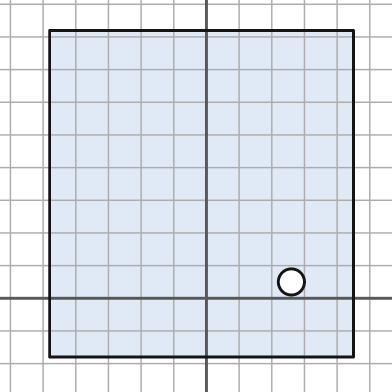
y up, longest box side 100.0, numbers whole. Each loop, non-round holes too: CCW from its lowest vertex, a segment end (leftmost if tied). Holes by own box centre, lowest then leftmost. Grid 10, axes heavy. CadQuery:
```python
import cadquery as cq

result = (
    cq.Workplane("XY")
    .moveTo(-48.0, -18.0)
    .lineTo(45.0, -18.0)
    .lineTo(45.0, 82.0)
    .lineTo(-48.0, 82.0)
    .close()
    .moveTo(26.0, 5.0)
    .circle(4.0)
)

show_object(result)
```